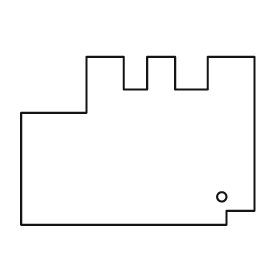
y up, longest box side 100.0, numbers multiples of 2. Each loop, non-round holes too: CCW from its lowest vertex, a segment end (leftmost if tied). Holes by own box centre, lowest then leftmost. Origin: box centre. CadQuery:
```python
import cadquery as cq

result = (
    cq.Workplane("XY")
    .moveTo(-50.0, -36.0)
    .lineTo(38.0, -36.0)
    .lineTo(38.0, -30.0)
    .lineTo(50.0, -30.0)
    .lineTo(50.0, 36.0)
    .lineTo(30.0, 36.0)
    .lineTo(30.0, 22.0)
    .lineTo(16.0, 22.0)
    .lineTo(16.0, 36.0)
    .lineTo(4.0, 36.0)
    .lineTo(4.0, 22.0)
    .lineTo(-6.0, 22.0)
    .lineTo(-6.0, 36.0)
    .lineTo(-22.0, 36.0)
    .lineTo(-22.0, 12.0)
    .lineTo(-50.0, 12.0)
    .close()
    .moveTo(36.0, -24.0)
    .circle(2.0)
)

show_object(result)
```